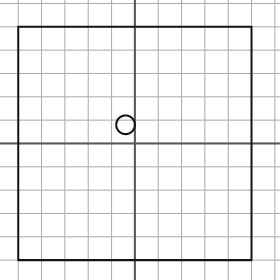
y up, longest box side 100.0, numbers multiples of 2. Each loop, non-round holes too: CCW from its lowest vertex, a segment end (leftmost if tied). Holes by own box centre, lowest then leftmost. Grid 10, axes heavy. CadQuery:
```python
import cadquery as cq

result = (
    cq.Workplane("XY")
    .moveTo(-50.0, -50.0)
    .lineTo(50.0, -50.0)
    .lineTo(50.0, 50.0)
    .lineTo(-50.0, 50.0)
    .close()
    .moveTo(-4.0, 8.0)
    .circle(4.0)
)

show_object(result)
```